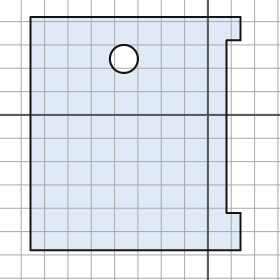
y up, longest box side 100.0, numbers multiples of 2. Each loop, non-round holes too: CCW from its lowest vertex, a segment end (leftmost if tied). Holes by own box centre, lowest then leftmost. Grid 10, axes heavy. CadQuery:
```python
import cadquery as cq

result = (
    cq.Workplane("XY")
    .moveTo(-76.0, -58.0)
    .lineTo(14.0, -58.0)
    .lineTo(14.0, -42.0)
    .lineTo(8.0, -42.0)
    .lineTo(8.0, 32.0)
    .lineTo(14.0, 32.0)
    .lineTo(14.0, 42.0)
    .lineTo(-76.0, 42.0)
    .close()
    .moveTo(-36.0, 24.0)
    .circle(6.0)
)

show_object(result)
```